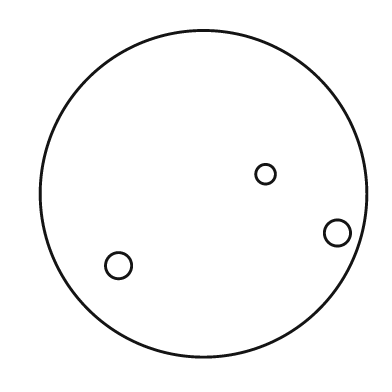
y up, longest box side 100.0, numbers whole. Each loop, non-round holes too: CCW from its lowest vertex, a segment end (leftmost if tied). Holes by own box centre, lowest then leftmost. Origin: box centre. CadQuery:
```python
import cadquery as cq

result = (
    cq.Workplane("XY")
    .moveTo(0.0, 0.0)
    .circle(50.0)
    .moveTo(-26.0, -22.0)
    .circle(4.0)
    .moveTo(41.0, -12.0)
    .circle(4.0)
    .moveTo(19.0, 6.0)
    .circle(3.0)
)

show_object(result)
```